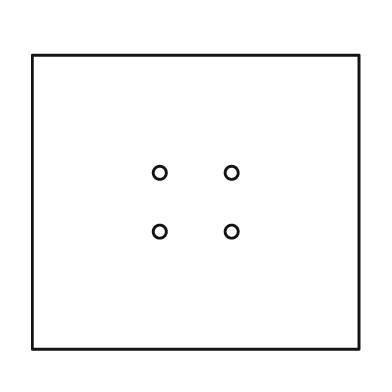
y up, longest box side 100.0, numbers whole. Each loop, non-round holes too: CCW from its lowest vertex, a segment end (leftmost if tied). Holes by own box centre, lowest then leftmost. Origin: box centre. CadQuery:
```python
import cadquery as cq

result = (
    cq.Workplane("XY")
    .moveTo(-50.0, -45.0)
    .lineTo(50.0, -45.0)
    .lineTo(50.0, 45.0)
    .lineTo(-50.0, 45.0)
    .close()
    .moveTo(-11.0, -9.0)
    .circle(2.0)
    .moveTo(11.0, -9.0)
    .circle(2.0)
    .moveTo(-11.0, 9.0)
    .circle(2.0)
    .moveTo(11.0, 9.0)
    .circle(2.0)
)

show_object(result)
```